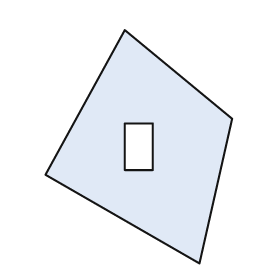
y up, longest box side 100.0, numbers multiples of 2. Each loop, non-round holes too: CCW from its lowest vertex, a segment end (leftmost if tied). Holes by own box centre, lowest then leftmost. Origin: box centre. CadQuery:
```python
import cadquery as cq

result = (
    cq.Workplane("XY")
    .moveTo(26.0, -50.0)
    .lineTo(40.0, 12.0)
    .lineTo(-6.0, 50.0)
    .lineTo(-40.0, -12.0)
    .close()
    .moveTo(-6.0, -10.0)
    .lineTo(6.0, -10.0)
    .lineTo(6.0, 10.0)
    .lineTo(-6.0, 10.0)
    .close()
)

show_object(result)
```